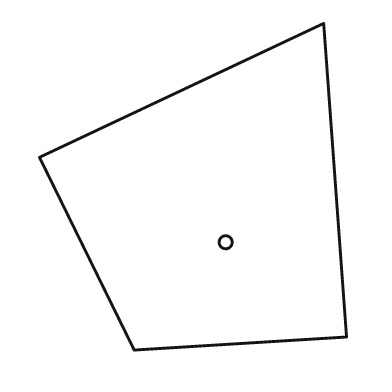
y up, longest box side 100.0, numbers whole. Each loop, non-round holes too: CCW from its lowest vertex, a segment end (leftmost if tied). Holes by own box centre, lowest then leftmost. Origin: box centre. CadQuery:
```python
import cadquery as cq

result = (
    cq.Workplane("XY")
    .moveTo(-18.0, -50.0)
    .lineTo(47.0, -46.0)
    .lineTo(40.0, 50.0)
    .lineTo(-47.0, 9.0)
    .close()
    .moveTo(10.0, -17.0)
    .circle(2.0)
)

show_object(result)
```